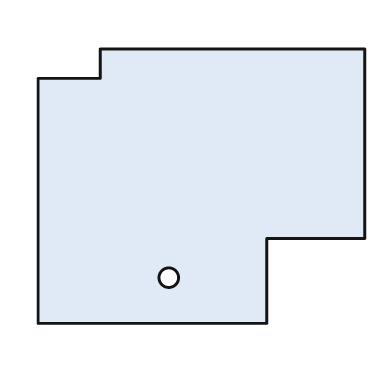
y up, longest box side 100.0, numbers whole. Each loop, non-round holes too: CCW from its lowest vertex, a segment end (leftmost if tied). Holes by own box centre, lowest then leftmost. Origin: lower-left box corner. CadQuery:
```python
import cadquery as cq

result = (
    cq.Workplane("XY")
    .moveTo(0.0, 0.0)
    .lineTo(70.0, 0.0)
    .lineTo(70.0, 26.0)
    .lineTo(100.0, 26.0)
    .lineTo(100.0, 84.0)
    .lineTo(19.0, 84.0)
    .lineTo(19.0, 75.0)
    .lineTo(0.0, 75.0)
    .close()
    .moveTo(40.0, 14.0)
    .circle(3.0)
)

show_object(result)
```